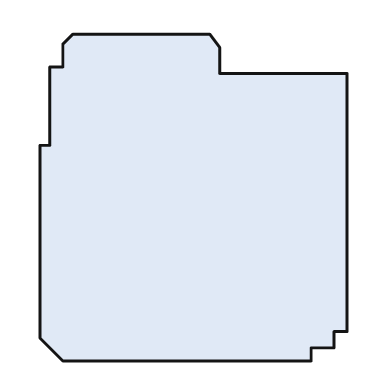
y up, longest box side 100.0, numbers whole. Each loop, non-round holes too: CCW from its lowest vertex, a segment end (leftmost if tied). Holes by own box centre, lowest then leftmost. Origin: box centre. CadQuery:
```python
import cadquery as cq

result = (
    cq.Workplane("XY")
    .moveTo(-40.0, -50.0)
    .lineTo(36.0, -50.0)
    .lineTo(36.0, -46.0)
    .lineTo(43.0, -46.0)
    .lineTo(43.0, -41.0)
    .lineTo(47.0, -41.0)
    .lineTo(47.0, 38.0)
    .lineTo(8.0, 38.0)
    .lineTo(8.0, 46.0)
    .lineTo(5.0, 50.0)
    .lineTo(-37.0, 50.0)
    .lineTo(-40.0, 47.0)
    .lineTo(-40.0, 40.0)
    .lineTo(-44.0, 40.0)
    .lineTo(-44.0, 16.0)
    .lineTo(-47.0, 16.0)
    .lineTo(-47.0, -43.0)
    .close()
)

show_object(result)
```